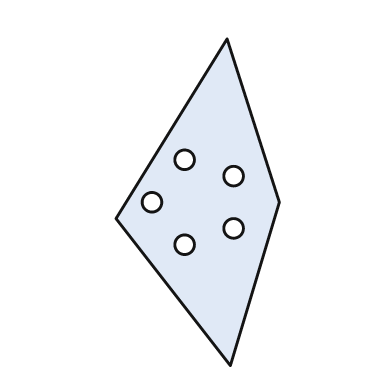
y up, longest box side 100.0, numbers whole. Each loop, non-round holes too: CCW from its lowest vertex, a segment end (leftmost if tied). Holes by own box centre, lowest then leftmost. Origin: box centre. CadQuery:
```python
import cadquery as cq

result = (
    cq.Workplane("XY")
    .moveTo(10.0, -50.0)
    .lineTo(25.0, 0.0)
    .lineTo(9.0, 50.0)
    .lineTo(-25.0, -5.0)
    .close()
    .moveTo(-4.0, -13.0)
    .circle(3.0)
    .moveTo(11.0, -8.0)
    .circle(3.0)
    .moveTo(-14.0, 0.0)
    .circle(3.0)
    .moveTo(11.0, 8.0)
    .circle(3.0)
    .moveTo(-4.0, 13.0)
    .circle(3.0)
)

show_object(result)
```